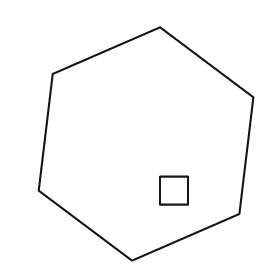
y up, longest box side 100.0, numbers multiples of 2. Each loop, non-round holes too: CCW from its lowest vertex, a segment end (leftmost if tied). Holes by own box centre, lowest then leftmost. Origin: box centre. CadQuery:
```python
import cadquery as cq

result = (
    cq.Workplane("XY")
    .moveTo(-6.0, -50.0)
    .lineTo(40.0, -30.0)
    .lineTo(46.0, 20.0)
    .lineTo(6.0, 50.0)
    .lineTo(-40.0, 30.0)
    .lineTo(-46.0, -20.0)
    .close()
    .moveTo(6.0, -26.0)
    .lineTo(18.0, -26.0)
    .lineTo(18.0, -14.0)
    .lineTo(6.0, -14.0)
    .close()
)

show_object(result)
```